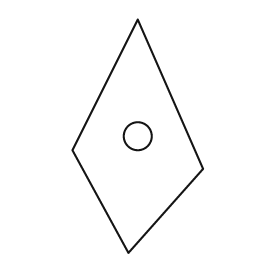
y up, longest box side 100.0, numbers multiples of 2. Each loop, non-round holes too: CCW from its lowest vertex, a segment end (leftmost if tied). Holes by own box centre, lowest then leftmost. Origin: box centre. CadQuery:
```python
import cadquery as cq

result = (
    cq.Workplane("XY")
    .moveTo(-4.0, -50.0)
    .lineTo(28.0, -14.0)
    .lineTo(0.0, 50.0)
    .lineTo(-28.0, -6.0)
    .close()
    .moveTo(0.0, 0.0)
    .circle(6.0)
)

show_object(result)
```